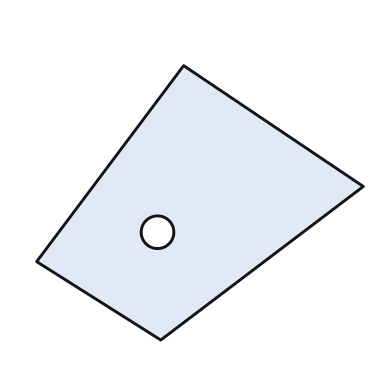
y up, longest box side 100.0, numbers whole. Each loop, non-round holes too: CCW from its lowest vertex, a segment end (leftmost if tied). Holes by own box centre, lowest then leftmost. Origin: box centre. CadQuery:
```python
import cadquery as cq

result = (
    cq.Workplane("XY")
    .moveTo(-12.0, -42.0)
    .lineTo(50.0, 5.0)
    .lineTo(-5.0, 42.0)
    .lineTo(-50.0, -18.0)
    .close()
    .moveTo(-13.0, -9.0)
    .circle(5.0)
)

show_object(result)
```